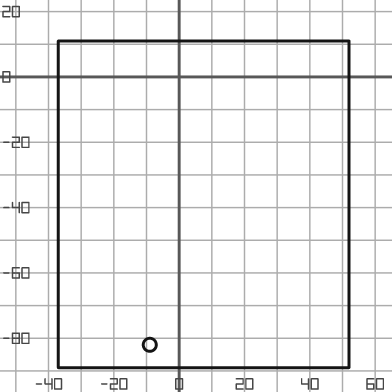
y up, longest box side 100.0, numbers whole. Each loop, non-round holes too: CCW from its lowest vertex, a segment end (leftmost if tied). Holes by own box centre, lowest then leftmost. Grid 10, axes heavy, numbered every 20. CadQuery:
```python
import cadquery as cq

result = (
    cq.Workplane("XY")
    .moveTo(-37.0, -89.0)
    .lineTo(52.0, -89.0)
    .lineTo(52.0, 11.0)
    .lineTo(-37.0, 11.0)
    .close()
    .moveTo(-9.0, -82.0)
    .circle(2.0)
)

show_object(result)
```